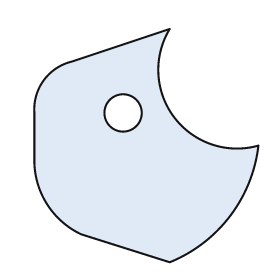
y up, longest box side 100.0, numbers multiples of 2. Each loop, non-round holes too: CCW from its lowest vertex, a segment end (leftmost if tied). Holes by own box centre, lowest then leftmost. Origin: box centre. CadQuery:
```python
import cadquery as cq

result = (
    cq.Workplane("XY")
    .moveTo(10.0, -50.0)
    .threePointArc((36.0, -30.0), (48.0, 0.0))
    .threePointArc((12.0, 12.0), (10.0, 50.0))
    .lineTo(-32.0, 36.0)
    .threePointArc((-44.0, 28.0), (-48.0, 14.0))
    .lineTo(-48.0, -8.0)
    .threePointArc((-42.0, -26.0), (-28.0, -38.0))
    .close()
    .moveTo(-10.0, 14.0)
    .circle(8.0)
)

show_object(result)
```